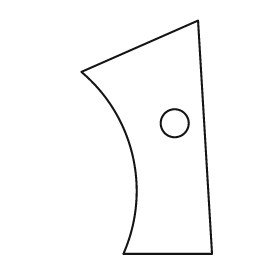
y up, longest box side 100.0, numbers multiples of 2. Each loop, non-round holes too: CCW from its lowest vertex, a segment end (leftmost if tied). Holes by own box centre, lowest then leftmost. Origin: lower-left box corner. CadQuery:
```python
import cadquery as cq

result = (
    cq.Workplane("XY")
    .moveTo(18.0, 0.0)
    .lineTo(56.0, 0.0)
    .lineTo(50.0, 100.0)
    .lineTo(0.0, 78.0)
    .threePointArc((22.0, 42.0), (18.0, 0.0))
    .close()
    .moveTo(40.0, 56.0)
    .circle(6.0)
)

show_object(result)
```